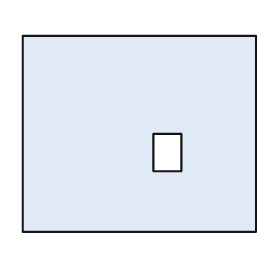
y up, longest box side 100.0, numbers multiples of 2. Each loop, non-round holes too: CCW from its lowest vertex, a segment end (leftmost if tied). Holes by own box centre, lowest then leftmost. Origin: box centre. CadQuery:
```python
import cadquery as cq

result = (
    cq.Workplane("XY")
    .moveTo(-50.0, -42.0)
    .lineTo(50.0, -42.0)
    .lineTo(50.0, 42.0)
    .lineTo(-50.0, 42.0)
    .close()
    .moveTo(6.0, -16.0)
    .lineTo(18.0, -16.0)
    .lineTo(18.0, 0.0)
    .lineTo(6.0, 0.0)
    .close()
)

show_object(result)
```